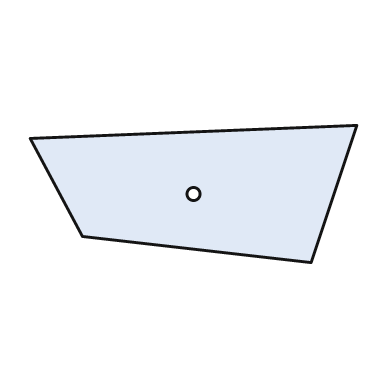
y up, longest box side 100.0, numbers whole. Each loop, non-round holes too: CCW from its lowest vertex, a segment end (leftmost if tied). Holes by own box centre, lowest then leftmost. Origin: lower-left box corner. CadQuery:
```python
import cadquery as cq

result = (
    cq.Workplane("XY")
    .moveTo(86.0, 0.0)
    .lineTo(100.0, 42.0)
    .lineTo(0.0, 38.0)
    .lineTo(16.0, 8.0)
    .close()
    .moveTo(50.0, 21.0)
    .circle(2.0)
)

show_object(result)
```